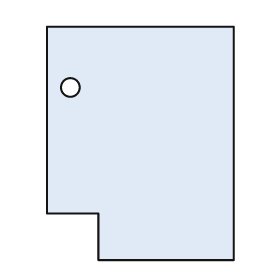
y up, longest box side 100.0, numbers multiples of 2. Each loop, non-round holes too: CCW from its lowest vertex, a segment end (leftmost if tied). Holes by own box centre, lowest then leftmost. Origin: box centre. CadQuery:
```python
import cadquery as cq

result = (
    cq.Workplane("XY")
    .moveTo(-18.0, -50.0)
    .lineTo(40.0, -50.0)
    .lineTo(40.0, 50.0)
    .lineTo(-40.0, 50.0)
    .lineTo(-40.0, -30.0)
    .lineTo(-18.0, -30.0)
    .close()
    .moveTo(-30.0, 24.0)
    .circle(4.0)
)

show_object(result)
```